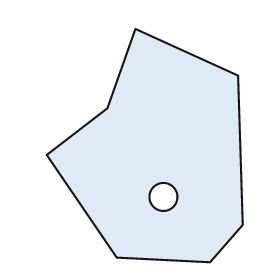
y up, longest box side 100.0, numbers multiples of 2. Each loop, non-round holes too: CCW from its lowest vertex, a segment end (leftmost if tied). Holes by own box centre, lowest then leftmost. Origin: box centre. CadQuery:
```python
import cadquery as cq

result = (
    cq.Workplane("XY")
    .moveTo(28.0, -50.0)
    .lineTo(42.0, -34.0)
    .lineTo(40.0, 30.0)
    .lineTo(-4.0, 50.0)
    .lineTo(-16.0, 16.0)
    .lineTo(-42.0, -4.0)
    .lineTo(-12.0, -48.0)
    .close()
    .moveTo(8.0, -22.0)
    .circle(6.0)
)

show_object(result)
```